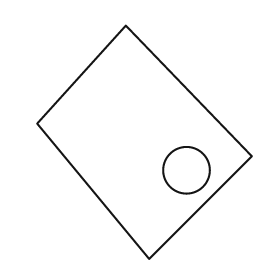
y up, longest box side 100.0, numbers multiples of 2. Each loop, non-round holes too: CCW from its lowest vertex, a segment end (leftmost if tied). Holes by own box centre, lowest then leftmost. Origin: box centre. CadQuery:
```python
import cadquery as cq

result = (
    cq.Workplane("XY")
    .moveTo(2.0, -50.0)
    .lineTo(46.0, -6.0)
    .lineTo(-8.0, 50.0)
    .lineTo(-46.0, 8.0)
    .close()
    .moveTo(18.0, -12.0)
    .circle(10.0)
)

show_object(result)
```